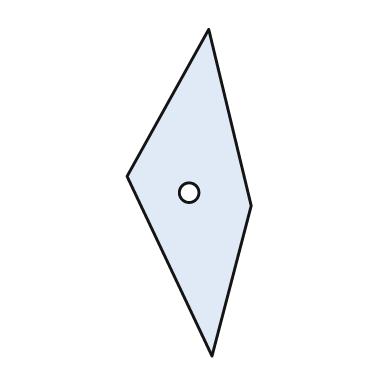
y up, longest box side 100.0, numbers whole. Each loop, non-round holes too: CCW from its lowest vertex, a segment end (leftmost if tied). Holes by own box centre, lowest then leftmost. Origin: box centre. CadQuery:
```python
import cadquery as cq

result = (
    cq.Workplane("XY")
    .moveTo(7.0, -50.0)
    .lineTo(19.0, -4.0)
    .lineTo(6.0, 50.0)
    .lineTo(-19.0, 5.0)
    .close()
    .moveTo(0.0, 0.0)
    .circle(3.0)
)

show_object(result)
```